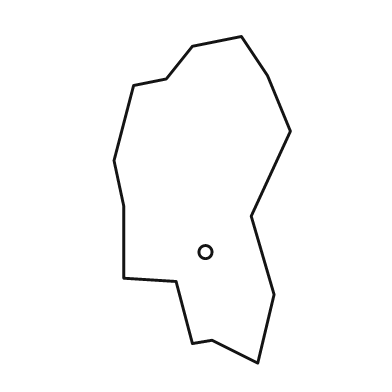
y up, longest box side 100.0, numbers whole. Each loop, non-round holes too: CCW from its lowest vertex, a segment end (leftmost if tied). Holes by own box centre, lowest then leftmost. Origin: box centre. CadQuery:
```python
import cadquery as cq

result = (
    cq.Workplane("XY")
    .moveTo(17.0, -50.0)
    .lineTo(22.0, -29.0)
    .lineTo(15.0, -5.0)
    .lineTo(27.0, 21.0)
    .lineTo(20.0, 38.0)
    .lineTo(12.0, 50.0)
    .lineTo(-3.0, 47.0)
    .lineTo(-11.0, 37.0)
    .lineTo(-21.0, 35.0)
    .lineTo(-27.0, 12.0)
    .lineTo(-24.0, -2.0)
    .lineTo(-24.0, -24.0)
    .lineTo(-8.0, -25.0)
    .lineTo(-3.0, -44.0)
    .lineTo(3.0, -43.0)
    .close()
    .moveTo(1.0, -16.0)
    .circle(2.0)
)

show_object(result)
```